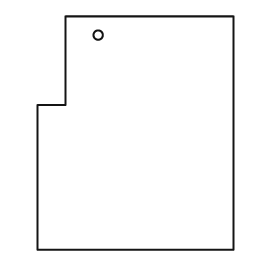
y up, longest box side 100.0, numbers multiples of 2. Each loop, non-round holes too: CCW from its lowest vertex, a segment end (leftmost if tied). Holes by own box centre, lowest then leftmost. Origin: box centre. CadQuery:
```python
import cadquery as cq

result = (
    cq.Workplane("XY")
    .moveTo(-42.0, -50.0)
    .lineTo(42.0, -50.0)
    .lineTo(42.0, 50.0)
    .lineTo(-30.0, 50.0)
    .lineTo(-30.0, 12.0)
    .lineTo(-42.0, 12.0)
    .close()
    .moveTo(-16.0, 42.0)
    .circle(2.0)
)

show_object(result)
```